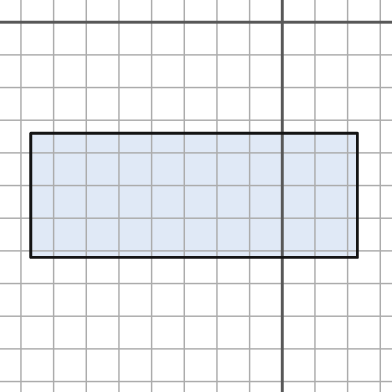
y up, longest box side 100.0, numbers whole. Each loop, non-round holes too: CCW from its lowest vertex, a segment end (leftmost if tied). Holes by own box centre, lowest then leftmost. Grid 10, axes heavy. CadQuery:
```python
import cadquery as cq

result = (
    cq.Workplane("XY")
    .moveTo(-77.0, -72.0)
    .lineTo(23.0, -72.0)
    .lineTo(23.0, -34.0)
    .lineTo(-77.0, -34.0)
    .close()
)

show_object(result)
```